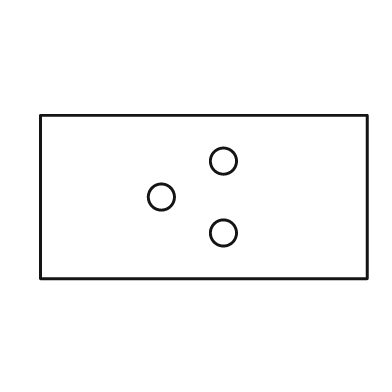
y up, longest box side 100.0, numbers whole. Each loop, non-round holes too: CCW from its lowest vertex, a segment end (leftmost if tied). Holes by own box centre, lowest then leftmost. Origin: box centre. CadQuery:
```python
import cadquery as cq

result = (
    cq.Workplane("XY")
    .moveTo(-50.0, -25.0)
    .lineTo(50.0, -25.0)
    .lineTo(50.0, 25.0)
    .lineTo(-50.0, 25.0)
    .close()
    .moveTo(6.0, -11.0)
    .circle(4.0)
    .moveTo(-13.0, 0.0)
    .circle(4.0)
    .moveTo(6.0, 11.0)
    .circle(4.0)
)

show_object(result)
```